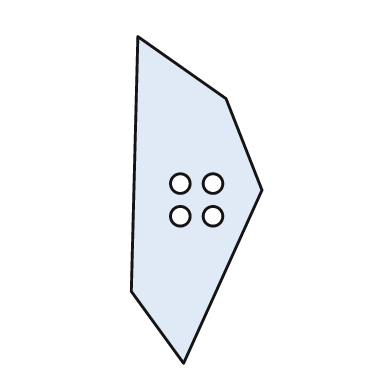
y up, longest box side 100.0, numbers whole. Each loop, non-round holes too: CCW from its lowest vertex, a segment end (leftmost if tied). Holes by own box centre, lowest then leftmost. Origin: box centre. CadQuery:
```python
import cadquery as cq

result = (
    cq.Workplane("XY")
    .moveTo(-4.0, -50.0)
    .lineTo(20.0, 3.0)
    .lineTo(9.0, 31.0)
    .lineTo(-18.0, 50.0)
    .lineTo(-20.0, -28.0)
    .close()
    .moveTo(-5.0, -5.0)
    .circle(3.0)
    .moveTo(5.0, -5.0)
    .circle(3.0)
    .moveTo(-5.0, 5.0)
    .circle(3.0)
    .moveTo(5.0, 5.0)
    .circle(3.0)
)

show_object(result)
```